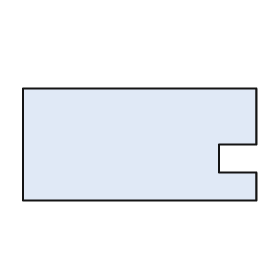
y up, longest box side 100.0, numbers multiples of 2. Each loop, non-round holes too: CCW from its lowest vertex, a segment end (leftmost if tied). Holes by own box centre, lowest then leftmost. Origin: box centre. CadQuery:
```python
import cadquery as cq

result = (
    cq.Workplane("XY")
    .moveTo(-50.0, -24.0)
    .lineTo(50.0, -24.0)
    .lineTo(50.0, -12.0)
    .lineTo(34.0, -12.0)
    .lineTo(34.0, 0.0)
    .lineTo(50.0, 0.0)
    .lineTo(50.0, 24.0)
    .lineTo(-50.0, 24.0)
    .close()
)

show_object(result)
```